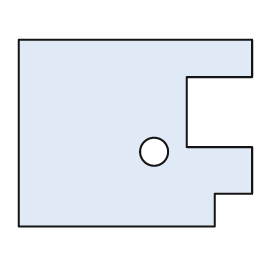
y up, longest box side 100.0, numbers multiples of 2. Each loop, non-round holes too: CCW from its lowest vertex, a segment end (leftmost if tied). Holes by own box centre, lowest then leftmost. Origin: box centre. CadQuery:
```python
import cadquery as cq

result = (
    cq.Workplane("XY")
    .moveTo(-50.0, -40.0)
    .lineTo(34.0, -40.0)
    .lineTo(34.0, -26.0)
    .lineTo(50.0, -26.0)
    .lineTo(50.0, -6.0)
    .lineTo(22.0, -6.0)
    .lineTo(22.0, 24.0)
    .lineTo(50.0, 24.0)
    .lineTo(50.0, 40.0)
    .lineTo(-50.0, 40.0)
    .close()
    .moveTo(8.0, -8.0)
    .circle(6.0)
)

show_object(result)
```